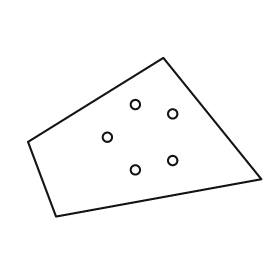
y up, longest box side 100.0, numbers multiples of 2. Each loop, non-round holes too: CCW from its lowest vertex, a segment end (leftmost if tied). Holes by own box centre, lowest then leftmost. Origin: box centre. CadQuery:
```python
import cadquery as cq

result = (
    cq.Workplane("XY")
    .moveTo(-38.0, -34.0)
    .lineTo(50.0, -18.0)
    .lineTo(8.0, 34.0)
    .lineTo(-50.0, -2.0)
    .close()
    .moveTo(-4.0, -14.0)
    .circle(2.0)
    .moveTo(12.0, -10.0)
    .circle(2.0)
    .moveTo(-16.0, 0.0)
    .circle(2.0)
    .moveTo(12.0, 10.0)
    .circle(2.0)
    .moveTo(-4.0, 14.0)
    .circle(2.0)
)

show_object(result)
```